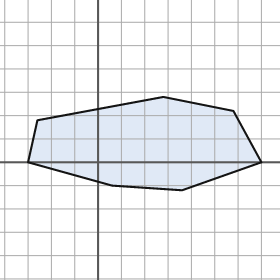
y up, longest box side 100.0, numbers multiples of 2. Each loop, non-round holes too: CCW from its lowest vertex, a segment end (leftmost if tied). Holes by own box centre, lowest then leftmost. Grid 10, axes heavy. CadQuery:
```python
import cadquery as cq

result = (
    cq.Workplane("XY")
    .moveTo(36.0, -12.0)
    .lineTo(70.0, 0.0)
    .lineTo(58.0, 22.0)
    .lineTo(28.0, 28.0)
    .lineTo(-26.0, 18.0)
    .lineTo(-30.0, 0.0)
    .lineTo(6.0, -10.0)
    .close()
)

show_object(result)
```